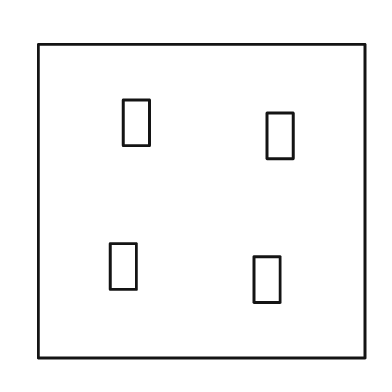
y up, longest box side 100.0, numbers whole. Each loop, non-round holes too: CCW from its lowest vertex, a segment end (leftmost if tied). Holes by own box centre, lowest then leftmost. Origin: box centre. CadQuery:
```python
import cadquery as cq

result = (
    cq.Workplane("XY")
    .moveTo(-50.0, -48.0)
    .lineTo(50.0, -48.0)
    .lineTo(50.0, 48.0)
    .lineTo(-50.0, 48.0)
    .close()
    .moveTo(16.0, -31.0)
    .lineTo(24.0, -31.0)
    .lineTo(24.0, -17.0)
    .lineTo(16.0, -17.0)
    .close()
    .moveTo(-28.0, -27.0)
    .lineTo(-20.0, -27.0)
    .lineTo(-20.0, -13.0)
    .lineTo(-28.0, -13.0)
    .close()
    .moveTo(20.0, 13.0)
    .lineTo(28.0, 13.0)
    .lineTo(28.0, 27.0)
    .lineTo(20.0, 27.0)
    .close()
    .moveTo(-24.0, 17.0)
    .lineTo(-16.0, 17.0)
    .lineTo(-16.0, 31.0)
    .lineTo(-24.0, 31.0)
    .close()
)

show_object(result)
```